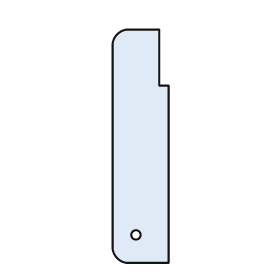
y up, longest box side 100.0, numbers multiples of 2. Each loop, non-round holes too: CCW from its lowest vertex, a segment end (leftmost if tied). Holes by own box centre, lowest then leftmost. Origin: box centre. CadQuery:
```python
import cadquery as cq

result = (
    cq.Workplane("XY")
    .moveTo(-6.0, -50.0)
    .lineTo(12.0, -50.0)
    .lineTo(12.0, 26.0)
    .lineTo(8.0, 26.0)
    .lineTo(8.0, 50.0)
    .lineTo(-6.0, 50.0)
    .threePointArc((-10.0, 48.0), (-12.0, 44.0))
    .lineTo(-12.0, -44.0)
    .threePointArc((-10.0, -48.0), (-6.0, -50.0))
    .close()
    .moveTo(-2.0, -38.0)
    .circle(2.0)
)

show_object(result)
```